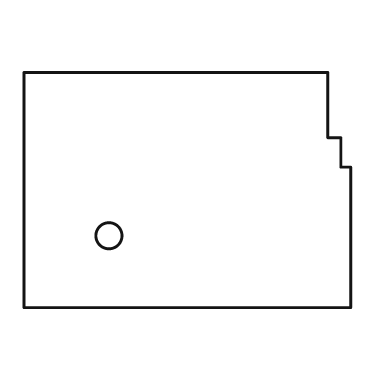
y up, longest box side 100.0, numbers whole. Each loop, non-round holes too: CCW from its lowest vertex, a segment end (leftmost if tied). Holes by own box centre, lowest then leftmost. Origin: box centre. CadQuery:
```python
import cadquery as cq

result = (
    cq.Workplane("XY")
    .moveTo(-50.0, -36.0)
    .lineTo(50.0, -36.0)
    .lineTo(50.0, 7.0)
    .lineTo(47.0, 7.0)
    .lineTo(47.0, 16.0)
    .lineTo(43.0, 16.0)
    .lineTo(43.0, 36.0)
    .lineTo(-50.0, 36.0)
    .close()
    .moveTo(-24.0, -14.0)
    .circle(4.0)
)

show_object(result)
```